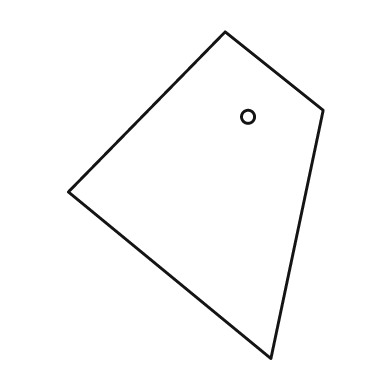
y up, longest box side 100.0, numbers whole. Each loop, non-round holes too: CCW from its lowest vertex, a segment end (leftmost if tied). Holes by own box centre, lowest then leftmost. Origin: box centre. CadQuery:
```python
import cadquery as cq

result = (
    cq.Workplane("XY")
    .moveTo(23.0, -50.0)
    .lineTo(39.0, 26.0)
    .lineTo(9.0, 50.0)
    .lineTo(-39.0, 1.0)
    .close()
    .moveTo(16.0, 24.0)
    .circle(2.0)
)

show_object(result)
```